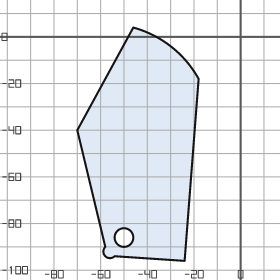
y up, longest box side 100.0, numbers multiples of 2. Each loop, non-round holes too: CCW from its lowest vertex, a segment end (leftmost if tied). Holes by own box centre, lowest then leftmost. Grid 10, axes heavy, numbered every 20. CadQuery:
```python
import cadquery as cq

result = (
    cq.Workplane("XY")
    .moveTo(-24.0, -96.0)
    .lineTo(-18.0, -18.0)
    .threePointArc((-30.0, -4.0), (-46.0, 4.0))
    .lineTo(-70.0, -40.0)
    .lineTo(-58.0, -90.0)
    .threePointArc((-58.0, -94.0), (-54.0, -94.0))
    .close()
    .moveTo(-50.0, -86.0)
    .circle(4.0)
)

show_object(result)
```